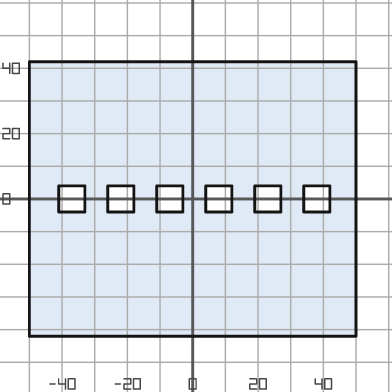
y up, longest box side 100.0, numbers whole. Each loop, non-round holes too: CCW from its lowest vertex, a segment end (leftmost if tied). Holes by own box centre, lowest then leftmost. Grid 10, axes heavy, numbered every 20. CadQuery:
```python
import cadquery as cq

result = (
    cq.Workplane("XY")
    .moveTo(-50.0, -42.0)
    .lineTo(50.0, -42.0)
    .lineTo(50.0, 42.0)
    .lineTo(-50.0, 42.0)
    .close()
    .moveTo(-41.0, -4.0)
    .lineTo(-33.0, -4.0)
    .lineTo(-33.0, 4.0)
    .lineTo(-41.0, 4.0)
    .close()
    .moveTo(-26.0, -4.0)
    .lineTo(-18.0, -4.0)
    .lineTo(-18.0, 4.0)
    .lineTo(-26.0, 4.0)
    .close()
    .moveTo(-11.0, -4.0)
    .lineTo(-3.0, -4.0)
    .lineTo(-3.0, 4.0)
    .lineTo(-11.0, 4.0)
    .close()
    .moveTo(4.0, -4.0)
    .lineTo(12.0, -4.0)
    .lineTo(12.0, 4.0)
    .lineTo(4.0, 4.0)
    .close()
    .moveTo(19.0, -4.0)
    .lineTo(27.0, -4.0)
    .lineTo(27.0, 4.0)
    .lineTo(19.0, 4.0)
    .close()
    .moveTo(34.0, -4.0)
    .lineTo(42.0, -4.0)
    .lineTo(42.0, 4.0)
    .lineTo(34.0, 4.0)
    .close()
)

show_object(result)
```